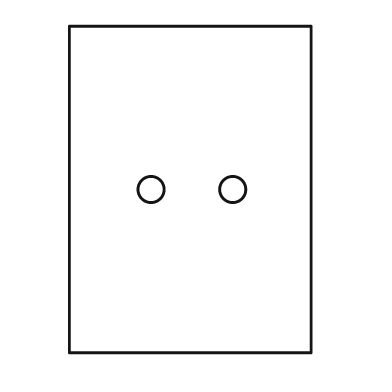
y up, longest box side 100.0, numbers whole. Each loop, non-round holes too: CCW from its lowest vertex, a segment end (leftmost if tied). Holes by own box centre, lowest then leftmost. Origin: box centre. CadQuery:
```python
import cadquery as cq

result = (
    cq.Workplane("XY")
    .moveTo(-37.0, -50.0)
    .lineTo(37.0, -50.0)
    .lineTo(37.0, 50.0)
    .lineTo(-37.0, 50.0)
    .close()
    .moveTo(-12.0, 0.0)
    .circle(4.0)
    .moveTo(13.0, 0.0)
    .circle(4.0)
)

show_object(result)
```